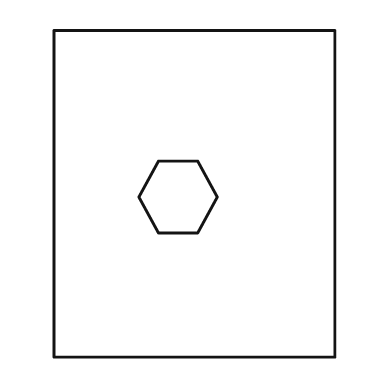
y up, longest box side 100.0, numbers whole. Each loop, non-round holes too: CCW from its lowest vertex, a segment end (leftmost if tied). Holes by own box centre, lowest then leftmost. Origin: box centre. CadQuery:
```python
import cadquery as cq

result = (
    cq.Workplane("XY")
    .moveTo(-43.0, -50.0)
    .lineTo(43.0, -50.0)
    .lineTo(43.0, 50.0)
    .lineTo(-43.0, 50.0)
    .close()
    .moveTo(-11.0, -12.0)
    .lineTo(1.0, -12.0)
    .lineTo(7.0, -1.0)
    .lineTo(1.0, 10.0)
    .lineTo(-11.0, 10.0)
    .lineTo(-17.0, -1.0)
    .close()
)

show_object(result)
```